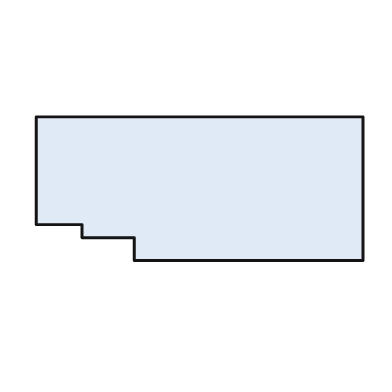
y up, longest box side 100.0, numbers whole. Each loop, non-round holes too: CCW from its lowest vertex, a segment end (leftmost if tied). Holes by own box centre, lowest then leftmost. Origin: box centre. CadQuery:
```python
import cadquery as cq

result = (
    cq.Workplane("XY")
    .moveTo(-20.0, -22.0)
    .lineTo(50.0, -22.0)
    .lineTo(50.0, 22.0)
    .lineTo(-50.0, 22.0)
    .lineTo(-50.0, -11.0)
    .lineTo(-36.0, -11.0)
    .lineTo(-36.0, -15.0)
    .lineTo(-20.0, -15.0)
    .close()
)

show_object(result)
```